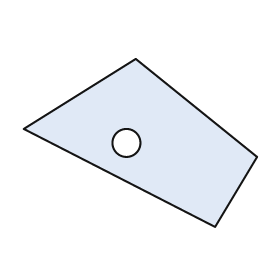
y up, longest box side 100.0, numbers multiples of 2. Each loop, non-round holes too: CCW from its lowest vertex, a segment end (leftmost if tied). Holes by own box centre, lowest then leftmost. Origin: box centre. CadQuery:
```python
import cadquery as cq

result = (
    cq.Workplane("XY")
    .moveTo(32.0, -36.0)
    .lineTo(50.0, -6.0)
    .lineTo(-2.0, 36.0)
    .lineTo(-50.0, 6.0)
    .close()
    .moveTo(-6.0, 0.0)
    .circle(6.0)
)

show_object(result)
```